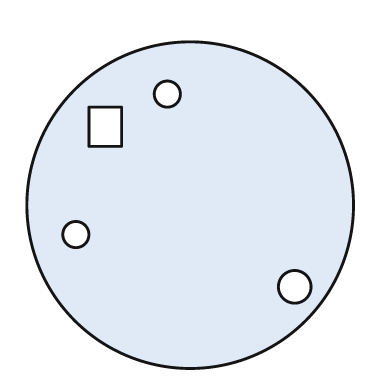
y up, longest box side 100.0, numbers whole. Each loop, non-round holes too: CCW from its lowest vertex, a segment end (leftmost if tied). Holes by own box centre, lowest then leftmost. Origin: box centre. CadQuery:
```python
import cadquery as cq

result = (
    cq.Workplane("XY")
    .moveTo(0.0, 0.0)
    .circle(50.0)
    .moveTo(32.0, -25.0)
    .circle(5.0)
    .moveTo(-35.0, -9.0)
    .circle(4.0)
    .moveTo(-31.0, 18.0)
    .lineTo(-21.0, 18.0)
    .lineTo(-21.0, 30.0)
    .lineTo(-31.0, 30.0)
    .close()
    .moveTo(-7.0, 34.0)
    .circle(4.0)
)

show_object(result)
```